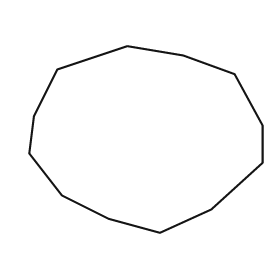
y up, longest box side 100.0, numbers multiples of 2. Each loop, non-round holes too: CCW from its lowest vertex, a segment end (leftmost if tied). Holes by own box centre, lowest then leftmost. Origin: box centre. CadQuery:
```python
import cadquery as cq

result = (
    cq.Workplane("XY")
    .moveTo(6.0, -40.0)
    .lineTo(28.0, -30.0)
    .lineTo(50.0, -10.0)
    .lineTo(50.0, 6.0)
    .lineTo(38.0, 28.0)
    .lineTo(16.0, 36.0)
    .lineTo(-8.0, 40.0)
    .lineTo(-38.0, 30.0)
    .lineTo(-48.0, 10.0)
    .lineTo(-50.0, -6.0)
    .lineTo(-36.0, -24.0)
    .lineTo(-16.0, -34.0)
    .close()
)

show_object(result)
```